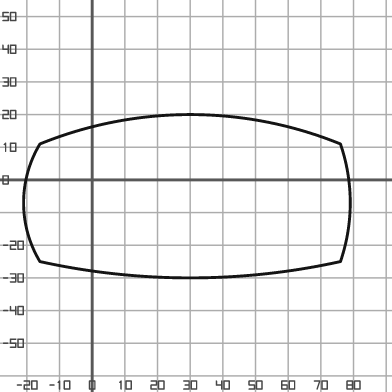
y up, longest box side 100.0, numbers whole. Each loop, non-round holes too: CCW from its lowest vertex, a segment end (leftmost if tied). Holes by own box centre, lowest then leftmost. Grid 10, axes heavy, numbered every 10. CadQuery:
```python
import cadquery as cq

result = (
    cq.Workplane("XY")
    .moveTo(-16.0, -25.0)
    .threePointArc((30.0, -30.0), (76.0, -25.0))
    .threePointArc((79.0, -7.0), (76.0, 11.0))
    .threePointArc((30.0, 20.0), (-16.0, 11.0))
    .threePointArc((-21.0, -7.0), (-16.0, -25.0))
    .close()
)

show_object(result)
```